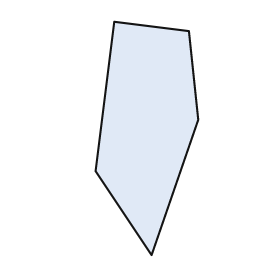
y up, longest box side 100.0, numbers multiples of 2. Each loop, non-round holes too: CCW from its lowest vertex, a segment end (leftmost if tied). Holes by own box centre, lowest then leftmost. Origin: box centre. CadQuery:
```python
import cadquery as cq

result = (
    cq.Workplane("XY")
    .moveTo(2.0, -50.0)
    .lineTo(22.0, 8.0)
    .lineTo(18.0, 46.0)
    .lineTo(-14.0, 50.0)
    .lineTo(-22.0, -14.0)
    .close()
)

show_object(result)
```